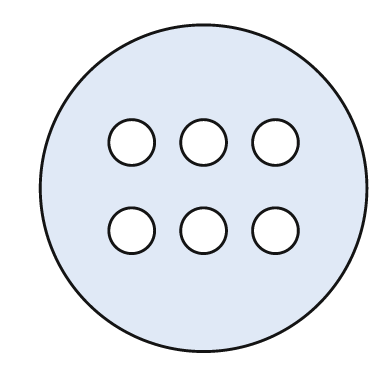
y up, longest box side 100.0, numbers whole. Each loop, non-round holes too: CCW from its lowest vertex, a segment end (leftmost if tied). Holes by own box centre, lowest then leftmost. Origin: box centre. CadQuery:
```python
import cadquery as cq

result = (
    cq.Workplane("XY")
    .moveTo(0.0, 0.0)
    .circle(50.0)
    .moveTo(-22.0, -13.0)
    .circle(7.0)
    .moveTo(0.0, -13.0)
    .circle(7.0)
    .moveTo(22.0, -13.0)
    .circle(7.0)
    .moveTo(-22.0, 14.0)
    .circle(7.0)
    .moveTo(0.0, 14.0)
    .circle(7.0)
    .moveTo(22.0, 14.0)
    .circle(7.0)
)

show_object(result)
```